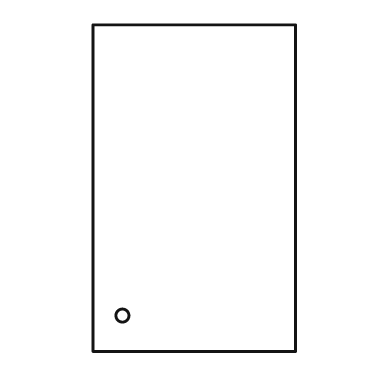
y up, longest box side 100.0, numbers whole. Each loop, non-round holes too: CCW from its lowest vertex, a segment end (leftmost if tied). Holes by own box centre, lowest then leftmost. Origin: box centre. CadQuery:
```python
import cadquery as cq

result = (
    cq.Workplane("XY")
    .moveTo(-31.0, -50.0)
    .lineTo(31.0, -50.0)
    .lineTo(31.0, 50.0)
    .lineTo(-31.0, 50.0)
    .close()
    .moveTo(-22.0, -39.0)
    .circle(2.0)
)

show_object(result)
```